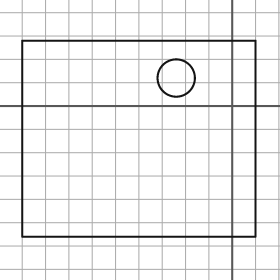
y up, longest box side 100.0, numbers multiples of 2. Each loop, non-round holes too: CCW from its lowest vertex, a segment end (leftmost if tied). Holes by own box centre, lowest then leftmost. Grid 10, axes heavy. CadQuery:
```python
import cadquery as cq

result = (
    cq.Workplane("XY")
    .moveTo(-90.0, -56.0)
    .lineTo(10.0, -56.0)
    .lineTo(10.0, 28.0)
    .lineTo(-90.0, 28.0)
    .close()
    .moveTo(-24.0, 12.0)
    .circle(8.0)
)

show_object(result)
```